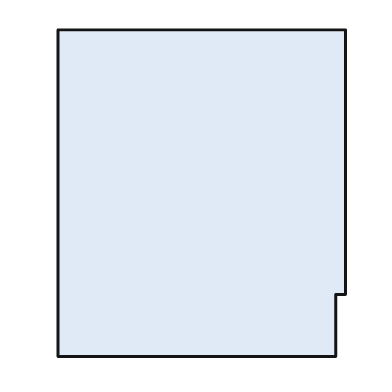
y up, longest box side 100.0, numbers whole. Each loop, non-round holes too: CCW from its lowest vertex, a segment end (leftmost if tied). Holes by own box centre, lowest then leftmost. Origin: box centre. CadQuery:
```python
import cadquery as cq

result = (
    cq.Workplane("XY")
    .moveTo(-44.0, -50.0)
    .lineTo(41.0, -50.0)
    .lineTo(41.0, -31.0)
    .lineTo(44.0, -31.0)
    .lineTo(44.0, 50.0)
    .lineTo(-44.0, 50.0)
    .close()
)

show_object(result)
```